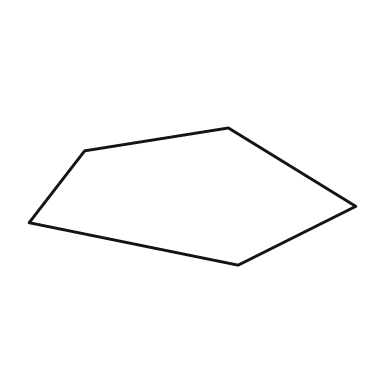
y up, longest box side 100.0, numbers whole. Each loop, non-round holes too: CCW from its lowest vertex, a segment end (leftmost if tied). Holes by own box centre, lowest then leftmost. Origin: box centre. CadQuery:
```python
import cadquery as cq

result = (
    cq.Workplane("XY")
    .moveTo(14.0, -21.0)
    .lineTo(50.0, -3.0)
    .lineTo(11.0, 21.0)
    .lineTo(-33.0, 14.0)
    .lineTo(-50.0, -8.0)
    .close()
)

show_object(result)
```